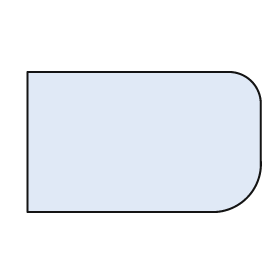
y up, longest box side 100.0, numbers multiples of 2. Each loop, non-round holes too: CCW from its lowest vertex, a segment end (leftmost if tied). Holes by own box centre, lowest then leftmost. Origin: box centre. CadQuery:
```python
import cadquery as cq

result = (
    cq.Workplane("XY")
    .moveTo(-50.0, -30.0)
    .lineTo(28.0, -30.0)
    .threePointArc((44.0, -24.0), (50.0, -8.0))
    .lineTo(50.0, 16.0)
    .threePointArc((46.0, 26.0), (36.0, 30.0))
    .lineTo(-50.0, 30.0)
    .close()
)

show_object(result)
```